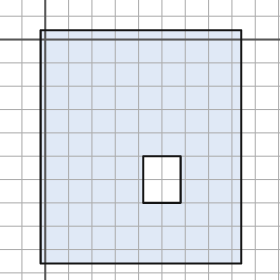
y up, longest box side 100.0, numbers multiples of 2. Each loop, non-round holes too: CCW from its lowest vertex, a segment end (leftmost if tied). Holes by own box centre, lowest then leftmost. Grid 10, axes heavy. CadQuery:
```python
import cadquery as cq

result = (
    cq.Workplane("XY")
    .moveTo(-2.0, -96.0)
    .lineTo(84.0, -96.0)
    .lineTo(84.0, 4.0)
    .lineTo(-2.0, 4.0)
    .close()
    .moveTo(42.0, -70.0)
    .lineTo(58.0, -70.0)
    .lineTo(58.0, -50.0)
    .lineTo(42.0, -50.0)
    .close()
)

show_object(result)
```